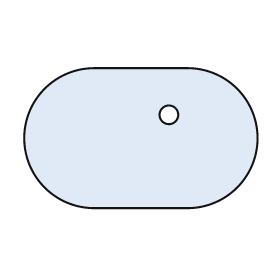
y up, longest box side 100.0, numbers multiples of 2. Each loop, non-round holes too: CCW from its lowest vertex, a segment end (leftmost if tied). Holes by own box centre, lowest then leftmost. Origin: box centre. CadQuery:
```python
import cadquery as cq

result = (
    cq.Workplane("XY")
    .moveTo(-20.0, -30.0)
    .lineTo(20.0, -30.0)
    .threePointArc((50.0, 0.0), (20.0, 30.0))
    .lineTo(-20.0, 30.0)
    .threePointArc((-50.0, 0.0), (-20.0, -30.0))
    .close()
    .moveTo(12.0, 10.0)
    .circle(4.0)
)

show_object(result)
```